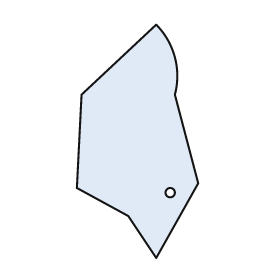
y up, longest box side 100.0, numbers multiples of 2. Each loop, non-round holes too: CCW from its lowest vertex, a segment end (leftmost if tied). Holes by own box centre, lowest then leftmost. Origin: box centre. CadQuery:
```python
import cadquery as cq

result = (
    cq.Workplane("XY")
    .moveTo(8.0, -50.0)
    .lineTo(26.0, -18.0)
    .lineTo(16.0, 20.0)
    .threePointArc((16.0, 36.0), (8.0, 50.0))
    .lineTo(-24.0, 20.0)
    .lineTo(-26.0, -20.0)
    .lineTo(-4.0, -32.0)
    .close()
    .moveTo(14.0, -22.0)
    .circle(2.0)
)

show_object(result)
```